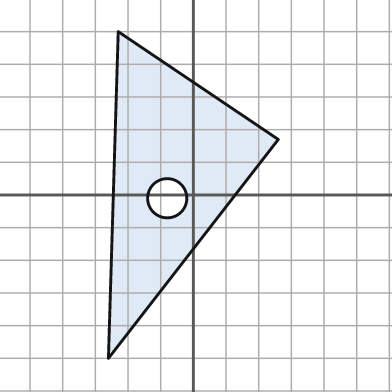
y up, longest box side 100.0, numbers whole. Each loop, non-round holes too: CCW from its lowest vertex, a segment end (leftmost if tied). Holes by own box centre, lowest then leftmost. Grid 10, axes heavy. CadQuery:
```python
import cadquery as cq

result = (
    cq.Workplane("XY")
    .moveTo(-26.0, -50.0)
    .lineTo(26.0, 17.0)
    .lineTo(-23.0, 50.0)
    .close()
    .moveTo(-8.0, -1.0)
    .circle(6.0)
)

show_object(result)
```